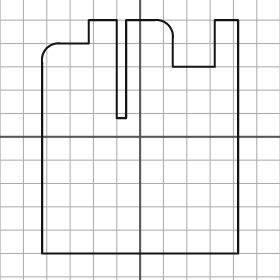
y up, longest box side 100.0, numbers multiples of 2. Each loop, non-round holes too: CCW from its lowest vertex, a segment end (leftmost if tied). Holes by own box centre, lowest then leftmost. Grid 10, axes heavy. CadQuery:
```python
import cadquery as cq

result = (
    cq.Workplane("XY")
    .moveTo(-42.0, -50.0)
    .lineTo(42.0, -50.0)
    .lineTo(42.0, 50.0)
    .lineTo(32.0, 50.0)
    .lineTo(32.0, 30.0)
    .lineTo(14.0, 30.0)
    .lineTo(14.0, 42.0)
    .threePointArc((12.0, 48.0), (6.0, 50.0))
    .lineTo(-6.0, 50.0)
    .lineTo(-6.0, 8.0)
    .lineTo(-10.0, 8.0)
    .lineTo(-10.0, 50.0)
    .lineTo(-22.0, 50.0)
    .lineTo(-22.0, 40.0)
    .lineTo(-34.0, 40.0)
    .threePointArc((-40.0, 38.0), (-42.0, 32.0))
    .close()
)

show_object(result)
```